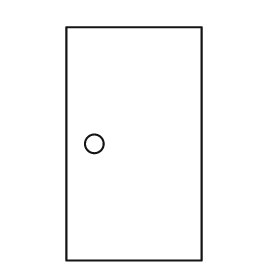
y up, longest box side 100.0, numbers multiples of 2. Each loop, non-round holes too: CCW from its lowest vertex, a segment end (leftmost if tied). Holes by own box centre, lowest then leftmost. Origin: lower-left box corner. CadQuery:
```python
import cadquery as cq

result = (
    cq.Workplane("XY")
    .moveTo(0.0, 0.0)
    .lineTo(58.0, 0.0)
    .lineTo(58.0, 100.0)
    .lineTo(0.0, 100.0)
    .close()
    .moveTo(12.0, 50.0)
    .circle(4.0)
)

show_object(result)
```